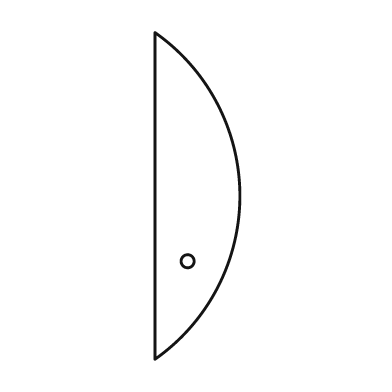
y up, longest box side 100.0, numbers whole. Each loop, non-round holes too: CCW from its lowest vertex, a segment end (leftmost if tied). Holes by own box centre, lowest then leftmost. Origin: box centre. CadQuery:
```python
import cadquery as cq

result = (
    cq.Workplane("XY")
    .moveTo(-13.0, -50.0)
    .threePointArc((13.0, 0.0), (-13.0, 50.0))
    .close()
    .moveTo(-3.0, -20.0)
    .circle(2.0)
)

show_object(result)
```